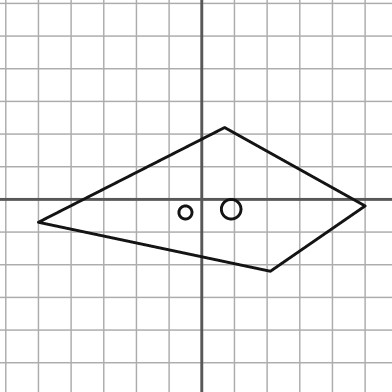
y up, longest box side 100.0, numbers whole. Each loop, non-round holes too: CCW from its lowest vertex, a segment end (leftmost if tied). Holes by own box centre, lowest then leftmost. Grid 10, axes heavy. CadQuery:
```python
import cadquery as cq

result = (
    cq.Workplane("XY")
    .moveTo(21.0, -22.0)
    .lineTo(50.0, -2.0)
    .lineTo(7.0, 22.0)
    .lineTo(-50.0, -7.0)
    .close()
    .moveTo(-5.0, -4.0)
    .circle(2.0)
    .moveTo(9.0, -3.0)
    .circle(3.0)
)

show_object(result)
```